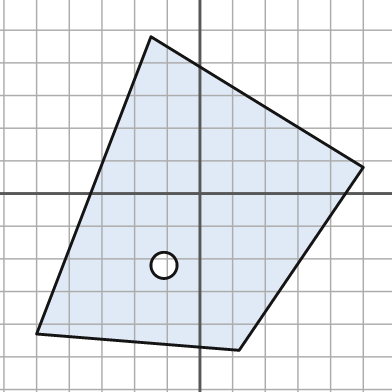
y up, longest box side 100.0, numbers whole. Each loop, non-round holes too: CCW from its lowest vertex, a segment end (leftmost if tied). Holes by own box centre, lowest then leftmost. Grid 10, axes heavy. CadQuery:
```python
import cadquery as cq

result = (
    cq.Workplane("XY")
    .moveTo(12.0, -48.0)
    .lineTo(50.0, 8.0)
    .lineTo(-15.0, 48.0)
    .lineTo(-50.0, -43.0)
    .close()
    .moveTo(-11.0, -22.0)
    .circle(4.0)
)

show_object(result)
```